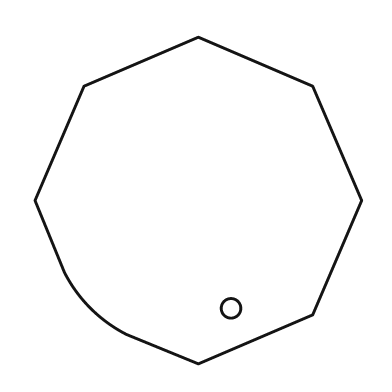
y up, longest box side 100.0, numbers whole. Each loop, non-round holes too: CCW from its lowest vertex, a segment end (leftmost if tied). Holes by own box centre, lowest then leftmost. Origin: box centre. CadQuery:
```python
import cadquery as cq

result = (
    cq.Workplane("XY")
    .moveTo(0.0, -50.0)
    .lineTo(35.0, -35.0)
    .lineTo(50.0, 0.0)
    .lineTo(35.0, 35.0)
    .lineTo(0.0, 50.0)
    .lineTo(-35.0, 35.0)
    .lineTo(-50.0, 0.0)
    .lineTo(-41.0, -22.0)
    .threePointArc((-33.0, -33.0), (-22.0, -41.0))
    .close()
    .moveTo(10.0, -33.0)
    .circle(3.0)
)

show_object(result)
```